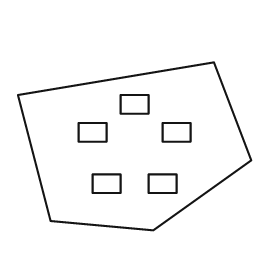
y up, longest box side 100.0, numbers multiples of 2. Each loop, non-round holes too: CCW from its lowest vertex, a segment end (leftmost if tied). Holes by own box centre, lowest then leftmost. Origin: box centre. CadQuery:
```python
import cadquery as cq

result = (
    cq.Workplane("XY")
    .moveTo(8.0, -36.0)
    .lineTo(50.0, -6.0)
    .lineTo(34.0, 36.0)
    .lineTo(-50.0, 22.0)
    .lineTo(-36.0, -32.0)
    .close()
    .moveTo(-18.0, -20.0)
    .lineTo(-6.0, -20.0)
    .lineTo(-6.0, -12.0)
    .lineTo(-18.0, -12.0)
    .close()
    .moveTo(6.0, -20.0)
    .lineTo(18.0, -20.0)
    .lineTo(18.0, -12.0)
    .lineTo(6.0, -12.0)
    .close()
    .moveTo(-24.0, 2.0)
    .lineTo(-12.0, 2.0)
    .lineTo(-12.0, 10.0)
    .lineTo(-24.0, 10.0)
    .close()
    .moveTo(12.0, 2.0)
    .lineTo(24.0, 2.0)
    .lineTo(24.0, 10.0)
    .lineTo(12.0, 10.0)
    .close()
    .moveTo(-6.0, 14.0)
    .lineTo(6.0, 14.0)
    .lineTo(6.0, 22.0)
    .lineTo(-6.0, 22.0)
    .close()
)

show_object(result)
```